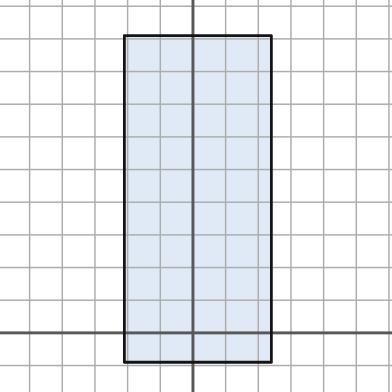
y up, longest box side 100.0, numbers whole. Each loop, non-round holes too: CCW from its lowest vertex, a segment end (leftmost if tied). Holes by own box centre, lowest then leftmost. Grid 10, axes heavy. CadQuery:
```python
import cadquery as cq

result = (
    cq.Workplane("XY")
    .moveTo(-21.0, -9.0)
    .lineTo(24.0, -9.0)
    .lineTo(24.0, 91.0)
    .lineTo(-21.0, 91.0)
    .close()
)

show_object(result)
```